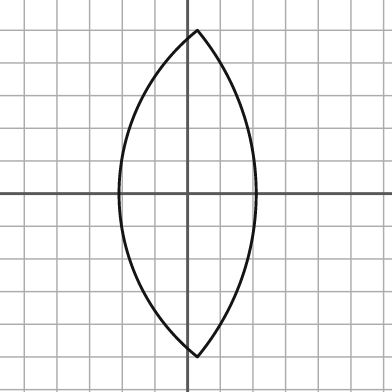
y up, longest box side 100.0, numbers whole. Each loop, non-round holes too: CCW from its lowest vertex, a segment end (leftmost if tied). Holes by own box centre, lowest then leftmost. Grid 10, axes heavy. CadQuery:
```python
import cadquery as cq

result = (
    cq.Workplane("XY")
    .moveTo(3.0, -50.0)
    .threePointArc((21.0, 0.0), (3.0, 50.0))
    .threePointArc((-21.0, 0.0), (3.0, -50.0))
    .close()
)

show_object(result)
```